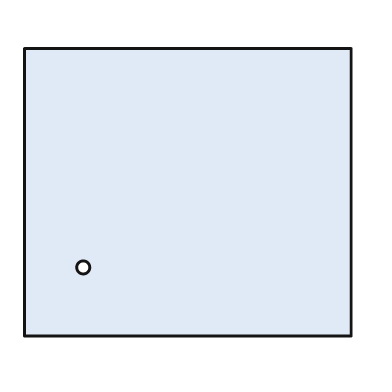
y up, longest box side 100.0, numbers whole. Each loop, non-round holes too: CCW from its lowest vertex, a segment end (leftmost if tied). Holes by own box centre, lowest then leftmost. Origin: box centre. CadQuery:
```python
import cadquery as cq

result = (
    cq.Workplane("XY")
    .moveTo(-50.0, -44.0)
    .lineTo(50.0, -44.0)
    .lineTo(50.0, 44.0)
    .lineTo(-50.0, 44.0)
    .close()
    .moveTo(-32.0, -23.0)
    .circle(2.0)
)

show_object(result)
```